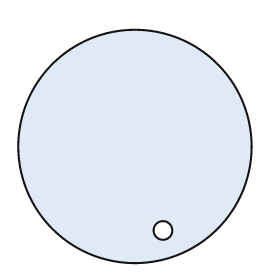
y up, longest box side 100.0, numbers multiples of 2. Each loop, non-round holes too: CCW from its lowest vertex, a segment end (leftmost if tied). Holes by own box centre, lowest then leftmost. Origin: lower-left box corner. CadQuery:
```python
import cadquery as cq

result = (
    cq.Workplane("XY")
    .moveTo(50.0, 50.0)
    .circle(50.0)
    .moveTo(62.0, 14.0)
    .circle(4.0)
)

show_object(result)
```